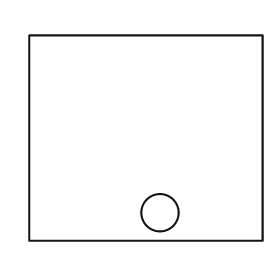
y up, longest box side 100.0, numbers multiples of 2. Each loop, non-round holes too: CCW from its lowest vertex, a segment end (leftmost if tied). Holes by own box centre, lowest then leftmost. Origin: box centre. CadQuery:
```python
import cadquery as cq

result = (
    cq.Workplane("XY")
    .moveTo(-50.0, -44.0)
    .lineTo(50.0, -44.0)
    .lineTo(50.0, 44.0)
    .lineTo(-50.0, 44.0)
    .close()
    .moveTo(6.0, -32.0)
    .circle(8.0)
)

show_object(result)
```